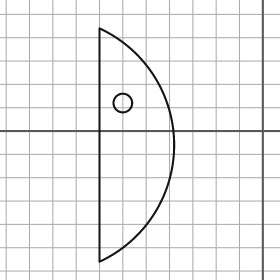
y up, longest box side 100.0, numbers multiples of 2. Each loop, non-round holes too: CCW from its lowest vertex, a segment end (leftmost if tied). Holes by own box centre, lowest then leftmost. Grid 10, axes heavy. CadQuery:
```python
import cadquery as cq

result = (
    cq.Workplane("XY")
    .moveTo(-70.0, -56.0)
    .threePointArc((-38.0, -6.0), (-70.0, 44.0))
    .close()
    .moveTo(-60.0, 12.0)
    .circle(4.0)
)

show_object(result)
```